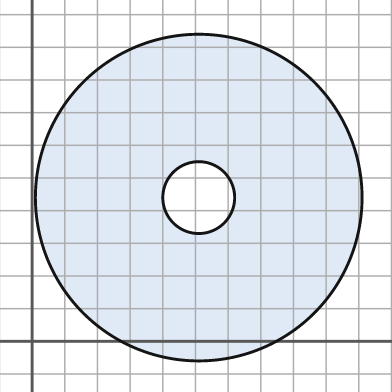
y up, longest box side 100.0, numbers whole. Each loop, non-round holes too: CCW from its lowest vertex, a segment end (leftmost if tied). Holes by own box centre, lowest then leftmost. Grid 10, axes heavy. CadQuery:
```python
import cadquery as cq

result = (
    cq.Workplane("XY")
    .moveTo(51.0, 44.0)
    .circle(50.0)
    .moveTo(51.0, 44.0)
    .circle(11.0)
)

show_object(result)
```